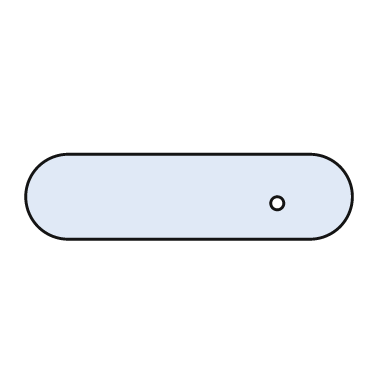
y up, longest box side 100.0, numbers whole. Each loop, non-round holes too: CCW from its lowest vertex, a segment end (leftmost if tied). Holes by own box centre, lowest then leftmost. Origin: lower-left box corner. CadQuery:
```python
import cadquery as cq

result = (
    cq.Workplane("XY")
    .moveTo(13.0, 0.0)
    .lineTo(87.0, 0.0)
    .threePointArc((100.0, 13.0), (87.0, 26.0))
    .lineTo(13.0, 26.0)
    .threePointArc((0.0, 13.0), (13.0, 0.0))
    .close()
    .moveTo(77.0, 11.0)
    .circle(2.0)
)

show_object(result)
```